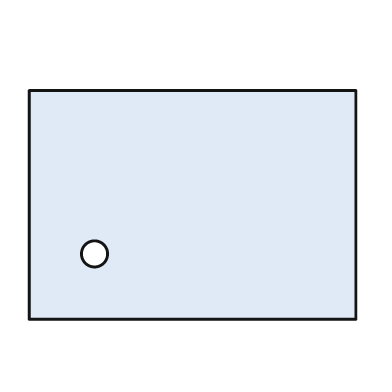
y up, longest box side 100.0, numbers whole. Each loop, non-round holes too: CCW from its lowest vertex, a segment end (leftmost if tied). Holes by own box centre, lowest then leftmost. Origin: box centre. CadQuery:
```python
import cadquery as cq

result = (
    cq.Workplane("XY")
    .moveTo(-50.0, -35.0)
    .lineTo(50.0, -35.0)
    .lineTo(50.0, 35.0)
    .lineTo(-50.0, 35.0)
    .close()
    .moveTo(-30.0, -15.0)
    .circle(4.0)
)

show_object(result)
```